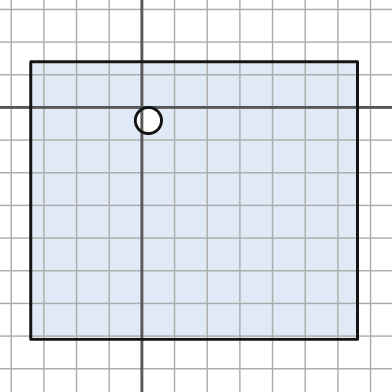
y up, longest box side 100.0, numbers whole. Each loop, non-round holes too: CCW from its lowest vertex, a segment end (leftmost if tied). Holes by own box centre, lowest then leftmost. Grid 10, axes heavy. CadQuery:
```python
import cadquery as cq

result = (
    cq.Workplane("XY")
    .moveTo(-34.0, -71.0)
    .lineTo(66.0, -71.0)
    .lineTo(66.0, 14.0)
    .lineTo(-34.0, 14.0)
    .close()
    .moveTo(2.0, -4.0)
    .circle(4.0)
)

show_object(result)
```